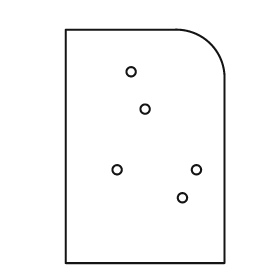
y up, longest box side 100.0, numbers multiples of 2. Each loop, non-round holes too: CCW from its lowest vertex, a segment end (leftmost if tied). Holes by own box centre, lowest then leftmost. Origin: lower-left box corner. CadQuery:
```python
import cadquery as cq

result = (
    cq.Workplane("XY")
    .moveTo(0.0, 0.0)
    .lineTo(68.0, 0.0)
    .lineTo(68.0, 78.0)
    .threePointArc((62.0, 94.0), (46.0, 100.0))
    .lineTo(0.0, 100.0)
    .close()
    .moveTo(50.0, 28.0)
    .circle(2.0)
    .moveTo(22.0, 40.0)
    .circle(2.0)
    .moveTo(56.0, 40.0)
    .circle(2.0)
    .moveTo(34.0, 66.0)
    .circle(2.0)
    .moveTo(28.0, 82.0)
    .circle(2.0)
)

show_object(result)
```